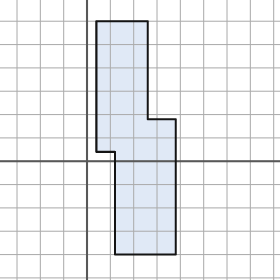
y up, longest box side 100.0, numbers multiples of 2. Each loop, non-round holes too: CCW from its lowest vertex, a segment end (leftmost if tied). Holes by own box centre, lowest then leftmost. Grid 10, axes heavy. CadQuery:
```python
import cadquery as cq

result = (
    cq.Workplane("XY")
    .moveTo(12.0, -40.0)
    .lineTo(38.0, -40.0)
    .lineTo(38.0, 18.0)
    .lineTo(26.0, 18.0)
    .lineTo(26.0, 60.0)
    .lineTo(4.0, 60.0)
    .lineTo(4.0, 4.0)
    .lineTo(12.0, 4.0)
    .close()
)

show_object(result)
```